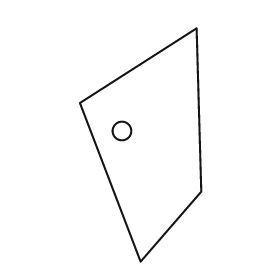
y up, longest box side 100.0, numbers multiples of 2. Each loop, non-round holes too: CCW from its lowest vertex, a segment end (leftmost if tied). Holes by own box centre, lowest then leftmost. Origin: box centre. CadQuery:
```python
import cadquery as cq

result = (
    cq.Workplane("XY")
    .moveTo(0.0, -50.0)
    .lineTo(26.0, -20.0)
    .lineTo(24.0, 50.0)
    .lineTo(-26.0, 18.0)
    .close()
    .moveTo(-8.0, 6.0)
    .circle(4.0)
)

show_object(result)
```